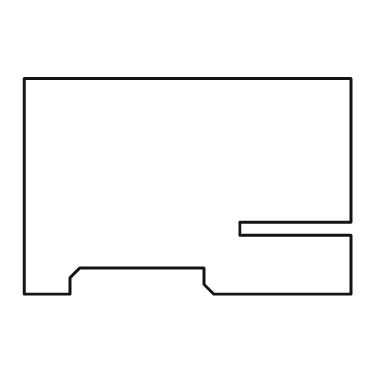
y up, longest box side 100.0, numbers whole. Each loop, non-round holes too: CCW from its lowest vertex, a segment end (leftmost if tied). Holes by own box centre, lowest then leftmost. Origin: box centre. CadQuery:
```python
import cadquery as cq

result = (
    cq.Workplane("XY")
    .moveTo(-50.0, -33.0)
    .lineTo(-36.0, -33.0)
    .lineTo(-36.0, -28.0)
    .lineTo(-33.0, -25.0)
    .lineTo(5.0, -25.0)
    .lineTo(5.0, -30.0)
    .lineTo(8.0, -33.0)
    .lineTo(50.0, -33.0)
    .lineTo(50.0, -15.0)
    .lineTo(16.0, -15.0)
    .lineTo(16.0, -11.0)
    .lineTo(50.0, -11.0)
    .lineTo(50.0, 33.0)
    .lineTo(-50.0, 33.0)
    .close()
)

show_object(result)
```